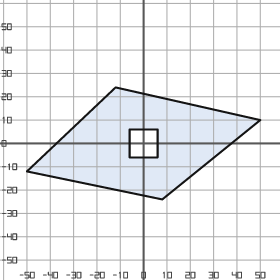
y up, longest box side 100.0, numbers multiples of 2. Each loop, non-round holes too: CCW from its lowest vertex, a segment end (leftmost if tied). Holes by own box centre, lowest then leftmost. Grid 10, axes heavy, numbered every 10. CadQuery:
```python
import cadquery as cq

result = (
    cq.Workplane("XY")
    .moveTo(8.0, -24.0)
    .lineTo(50.0, 10.0)
    .lineTo(-12.0, 24.0)
    .lineTo(-50.0, -12.0)
    .close()
    .moveTo(-6.0, -6.0)
    .lineTo(6.0, -6.0)
    .lineTo(6.0, 6.0)
    .lineTo(-6.0, 6.0)
    .close()
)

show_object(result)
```